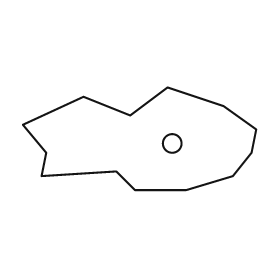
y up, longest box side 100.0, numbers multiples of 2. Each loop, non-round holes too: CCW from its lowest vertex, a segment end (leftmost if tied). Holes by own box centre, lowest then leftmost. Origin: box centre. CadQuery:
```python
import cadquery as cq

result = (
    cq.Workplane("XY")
    .moveTo(-2.0, -22.0)
    .lineTo(20.0, -22.0)
    .lineTo(40.0, -16.0)
    .lineTo(48.0, -6.0)
    .lineTo(50.0, 4.0)
    .lineTo(36.0, 14.0)
    .lineTo(12.0, 22.0)
    .lineTo(-4.0, 10.0)
    .lineTo(-24.0, 18.0)
    .lineTo(-50.0, 6.0)
    .lineTo(-40.0, -6.0)
    .lineTo(-42.0, -16.0)
    .lineTo(-10.0, -14.0)
    .close()
    .moveTo(14.0, -2.0)
    .circle(4.0)
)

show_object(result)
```